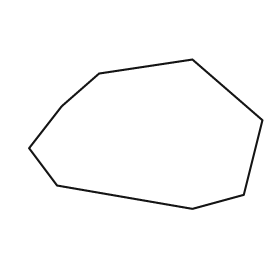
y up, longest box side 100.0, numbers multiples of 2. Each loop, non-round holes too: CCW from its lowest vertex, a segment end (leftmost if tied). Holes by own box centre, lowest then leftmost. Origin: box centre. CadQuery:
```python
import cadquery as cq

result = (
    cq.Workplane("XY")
    .moveTo(20.0, -32.0)
    .lineTo(42.0, -26.0)
    .lineTo(50.0, 6.0)
    .lineTo(20.0, 32.0)
    .lineTo(-20.0, 26.0)
    .lineTo(-36.0, 12.0)
    .lineTo(-50.0, -6.0)
    .lineTo(-38.0, -22.0)
    .close()
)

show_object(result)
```